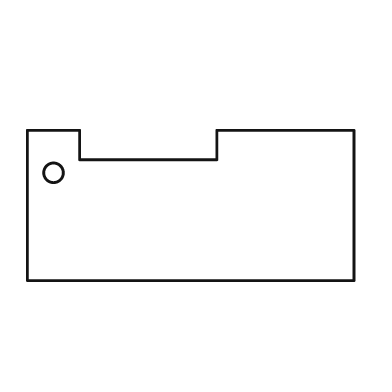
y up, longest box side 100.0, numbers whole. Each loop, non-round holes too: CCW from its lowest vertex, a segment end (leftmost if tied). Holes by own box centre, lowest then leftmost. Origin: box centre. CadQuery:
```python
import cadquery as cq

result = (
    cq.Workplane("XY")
    .moveTo(-50.0, -23.0)
    .lineTo(50.0, -23.0)
    .lineTo(50.0, 23.0)
    .lineTo(8.0, 23.0)
    .lineTo(8.0, 14.0)
    .lineTo(-34.0, 14.0)
    .lineTo(-34.0, 23.0)
    .lineTo(-50.0, 23.0)
    .close()
    .moveTo(-42.0, 10.0)
    .circle(3.0)
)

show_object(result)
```